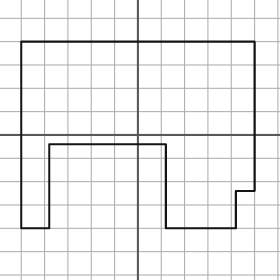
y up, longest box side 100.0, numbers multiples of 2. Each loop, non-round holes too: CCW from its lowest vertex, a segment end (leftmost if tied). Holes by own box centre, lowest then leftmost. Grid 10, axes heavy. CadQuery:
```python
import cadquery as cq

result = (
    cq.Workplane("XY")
    .moveTo(-50.0, -40.0)
    .lineTo(-38.0, -40.0)
    .lineTo(-38.0, -4.0)
    .lineTo(12.0, -4.0)
    .lineTo(12.0, -40.0)
    .lineTo(42.0, -40.0)
    .lineTo(42.0, -24.0)
    .lineTo(50.0, -24.0)
    .lineTo(50.0, 40.0)
    .lineTo(-50.0, 40.0)
    .close()
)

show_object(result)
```